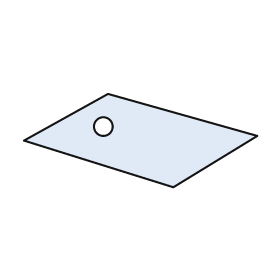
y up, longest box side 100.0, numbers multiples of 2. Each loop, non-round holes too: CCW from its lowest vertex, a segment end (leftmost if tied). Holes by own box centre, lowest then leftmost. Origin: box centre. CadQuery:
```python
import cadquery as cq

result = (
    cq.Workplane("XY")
    .moveTo(14.0, -20.0)
    .lineTo(50.0, 2.0)
    .lineTo(-14.0, 20.0)
    .lineTo(-50.0, 0.0)
    .close()
    .moveTo(-16.0, 6.0)
    .circle(4.0)
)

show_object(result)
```